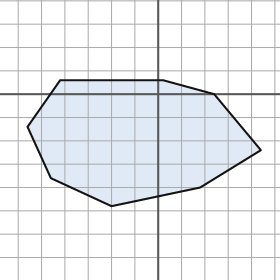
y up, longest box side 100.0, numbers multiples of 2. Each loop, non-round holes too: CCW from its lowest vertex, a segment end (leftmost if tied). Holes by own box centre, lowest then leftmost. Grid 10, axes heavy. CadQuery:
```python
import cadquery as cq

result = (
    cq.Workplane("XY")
    .moveTo(-20.0, -48.0)
    .lineTo(18.0, -40.0)
    .lineTo(44.0, -24.0)
    .lineTo(24.0, 0.0)
    .lineTo(2.0, 6.0)
    .lineTo(-42.0, 6.0)
    .lineTo(-56.0, -14.0)
    .lineTo(-46.0, -36.0)
    .close()
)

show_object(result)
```